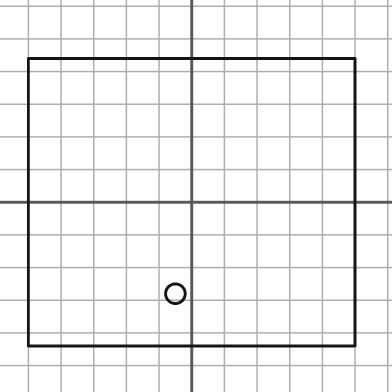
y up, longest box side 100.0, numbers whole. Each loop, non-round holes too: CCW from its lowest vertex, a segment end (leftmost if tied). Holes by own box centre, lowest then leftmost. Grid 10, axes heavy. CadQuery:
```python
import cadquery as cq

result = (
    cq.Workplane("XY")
    .moveTo(-50.0, -44.0)
    .lineTo(50.0, -44.0)
    .lineTo(50.0, 44.0)
    .lineTo(-50.0, 44.0)
    .close()
    .moveTo(-5.0, -28.0)
    .circle(3.0)
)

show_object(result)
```